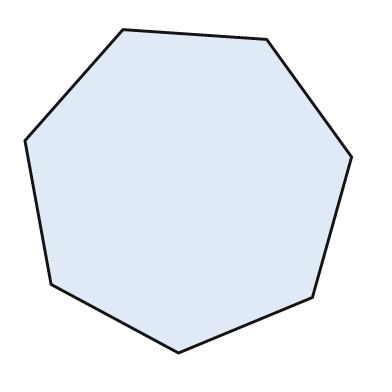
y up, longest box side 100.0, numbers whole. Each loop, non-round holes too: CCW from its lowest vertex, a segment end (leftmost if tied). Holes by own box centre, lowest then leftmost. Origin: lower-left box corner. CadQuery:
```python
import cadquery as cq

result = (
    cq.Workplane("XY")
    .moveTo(47.0, 0.0)
    .lineTo(88.0, 17.0)
    .lineTo(100.0, 60.0)
    .lineTo(74.0, 96.0)
    .lineTo(30.0, 99.0)
    .lineTo(0.0, 65.0)
    .lineTo(8.0, 21.0)
    .close()
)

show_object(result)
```